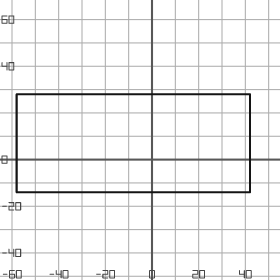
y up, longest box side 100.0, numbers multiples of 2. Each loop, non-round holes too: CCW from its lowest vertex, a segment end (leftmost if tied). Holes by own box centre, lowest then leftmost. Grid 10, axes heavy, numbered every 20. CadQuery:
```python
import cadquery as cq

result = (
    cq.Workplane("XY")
    .moveTo(-58.0, -14.0)
    .lineTo(42.0, -14.0)
    .lineTo(42.0, 28.0)
    .lineTo(-58.0, 28.0)
    .close()
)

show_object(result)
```